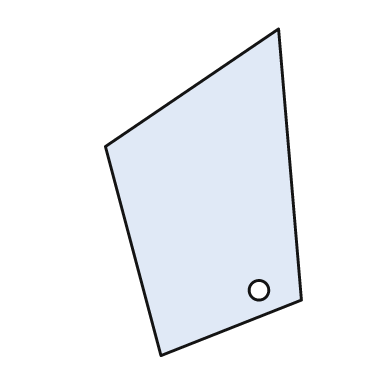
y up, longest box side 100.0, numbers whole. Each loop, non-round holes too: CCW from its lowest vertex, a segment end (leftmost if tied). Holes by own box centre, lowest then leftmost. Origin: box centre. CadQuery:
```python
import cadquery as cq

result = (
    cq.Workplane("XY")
    .moveTo(-13.0, -50.0)
    .lineTo(30.0, -33.0)
    .lineTo(23.0, 50.0)
    .lineTo(-30.0, 14.0)
    .close()
    .moveTo(17.0, -30.0)
    .circle(3.0)
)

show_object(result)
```